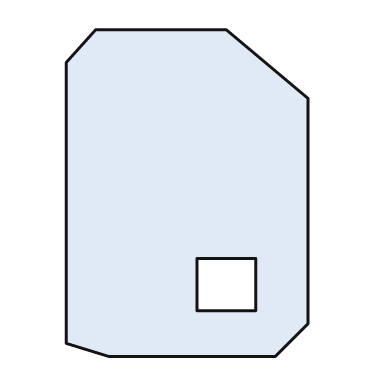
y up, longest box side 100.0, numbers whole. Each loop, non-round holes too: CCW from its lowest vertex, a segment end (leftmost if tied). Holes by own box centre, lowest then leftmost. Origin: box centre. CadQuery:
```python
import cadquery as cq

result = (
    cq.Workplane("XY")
    .moveTo(-24.0, -50.0)
    .lineTo(27.0, -50.0)
    .lineTo(37.0, -40.0)
    .lineTo(37.0, 29.0)
    .lineTo(12.0, 50.0)
    .lineTo(-28.0, 50.0)
    .lineTo(-37.0, 40.0)
    .lineTo(-37.0, -46.0)
    .close()
    .moveTo(3.0, -36.0)
    .lineTo(21.0, -36.0)
    .lineTo(21.0, -20.0)
    .lineTo(3.0, -20.0)
    .close()
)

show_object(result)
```